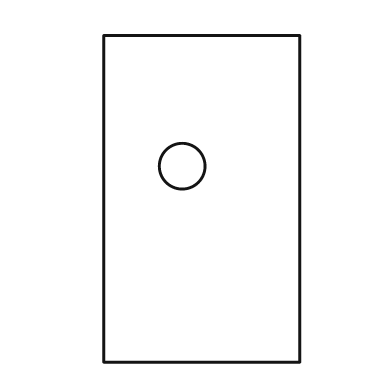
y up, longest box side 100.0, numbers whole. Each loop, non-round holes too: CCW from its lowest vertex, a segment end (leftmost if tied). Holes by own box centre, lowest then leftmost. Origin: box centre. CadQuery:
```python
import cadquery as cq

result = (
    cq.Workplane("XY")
    .moveTo(-30.0, -50.0)
    .lineTo(30.0, -50.0)
    .lineTo(30.0, 50.0)
    .lineTo(-30.0, 50.0)
    .close()
    .moveTo(-6.0, 10.0)
    .circle(7.0)
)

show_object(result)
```